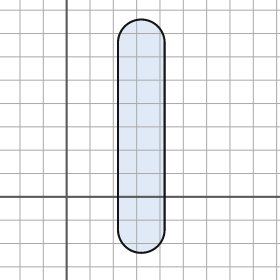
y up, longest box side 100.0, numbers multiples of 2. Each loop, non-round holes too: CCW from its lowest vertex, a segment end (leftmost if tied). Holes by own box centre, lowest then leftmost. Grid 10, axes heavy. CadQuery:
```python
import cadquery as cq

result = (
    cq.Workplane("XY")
    .moveTo(22.0, -14.0)
    .threePointArc((32.0, -24.0), (42.0, -14.0))
    .lineTo(42.0, 66.0)
    .threePointArc((32.0, 76.0), (22.0, 66.0))
    .close()
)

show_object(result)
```